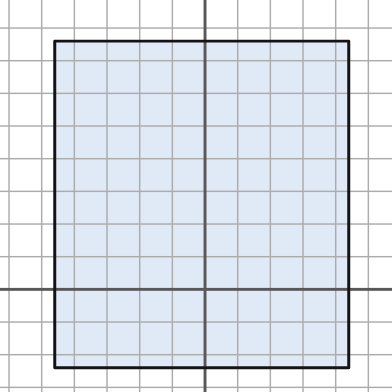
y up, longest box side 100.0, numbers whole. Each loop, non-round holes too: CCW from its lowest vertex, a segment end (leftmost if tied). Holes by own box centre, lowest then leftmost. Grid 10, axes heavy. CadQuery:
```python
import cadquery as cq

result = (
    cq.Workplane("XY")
    .moveTo(-46.0, -24.0)
    .lineTo(44.0, -24.0)
    .lineTo(44.0, 76.0)
    .lineTo(-46.0, 76.0)
    .close()
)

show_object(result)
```